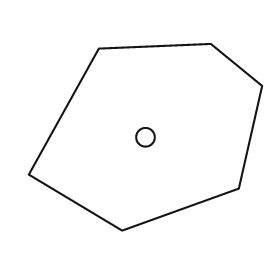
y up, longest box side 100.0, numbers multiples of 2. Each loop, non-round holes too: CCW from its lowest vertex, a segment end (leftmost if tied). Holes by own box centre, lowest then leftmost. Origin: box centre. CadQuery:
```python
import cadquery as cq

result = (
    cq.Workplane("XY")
    .moveTo(-10.0, -40.0)
    .lineTo(40.0, -22.0)
    .lineTo(50.0, 22.0)
    .lineTo(28.0, 40.0)
    .lineTo(-20.0, 38.0)
    .lineTo(-50.0, -16.0)
    .close()
    .moveTo(0.0, 0.0)
    .circle(4.0)
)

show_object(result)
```